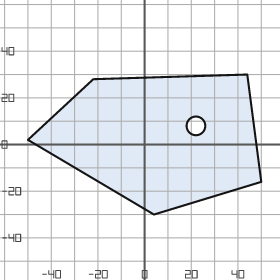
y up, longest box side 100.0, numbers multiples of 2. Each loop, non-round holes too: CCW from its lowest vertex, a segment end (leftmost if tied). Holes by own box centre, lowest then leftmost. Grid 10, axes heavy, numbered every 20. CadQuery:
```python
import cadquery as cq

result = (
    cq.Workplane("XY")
    .moveTo(4.0, -30.0)
    .lineTo(50.0, -16.0)
    .lineTo(44.0, 30.0)
    .lineTo(-22.0, 28.0)
    .lineTo(-50.0, 2.0)
    .close()
    .moveTo(22.0, 8.0)
    .circle(4.0)
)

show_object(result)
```